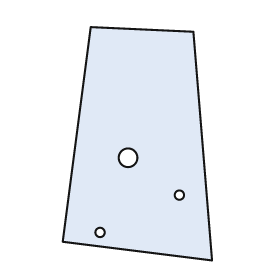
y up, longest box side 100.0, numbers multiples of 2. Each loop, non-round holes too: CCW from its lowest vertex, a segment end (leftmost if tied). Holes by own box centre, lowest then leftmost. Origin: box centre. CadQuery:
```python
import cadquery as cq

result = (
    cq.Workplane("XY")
    .moveTo(32.0, -50.0)
    .lineTo(24.0, 48.0)
    .lineTo(-20.0, 50.0)
    .lineTo(-32.0, -42.0)
    .close()
    .moveTo(-16.0, -38.0)
    .circle(2.0)
    .moveTo(18.0, -22.0)
    .circle(2.0)
    .moveTo(-4.0, -6.0)
    .circle(4.0)
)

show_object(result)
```